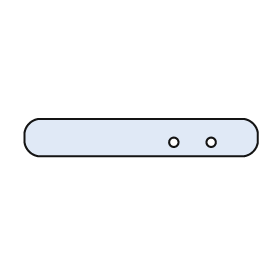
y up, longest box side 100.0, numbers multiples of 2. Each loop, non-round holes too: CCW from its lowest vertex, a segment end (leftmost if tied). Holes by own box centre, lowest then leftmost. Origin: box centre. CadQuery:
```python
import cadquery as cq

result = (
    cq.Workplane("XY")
    .moveTo(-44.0, -8.0)
    .lineTo(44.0, -8.0)
    .threePointArc((48.0, -6.0), (50.0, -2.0))
    .lineTo(50.0, 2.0)
    .threePointArc((48.0, 6.0), (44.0, 8.0))
    .lineTo(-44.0, 8.0)
    .threePointArc((-48.0, 6.0), (-50.0, 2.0))
    .lineTo(-50.0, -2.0)
    .threePointArc((-48.0, -6.0), (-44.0, -8.0))
    .close()
    .moveTo(14.0, -2.0)
    .circle(2.0)
    .moveTo(30.0, -2.0)
    .circle(2.0)
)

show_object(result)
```